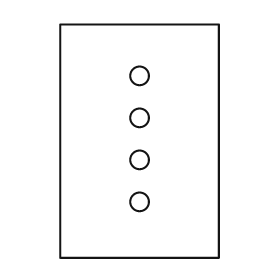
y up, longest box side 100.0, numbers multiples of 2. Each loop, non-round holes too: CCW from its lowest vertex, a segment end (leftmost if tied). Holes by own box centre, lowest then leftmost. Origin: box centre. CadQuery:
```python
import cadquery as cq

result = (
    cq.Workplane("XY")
    .moveTo(-34.0, -50.0)
    .lineTo(34.0, -50.0)
    .lineTo(34.0, 50.0)
    .lineTo(-34.0, 50.0)
    .close()
    .moveTo(0.0, -26.0)
    .circle(4.0)
    .moveTo(0.0, -8.0)
    .circle(4.0)
    .moveTo(0.0, 10.0)
    .circle(4.0)
    .moveTo(0.0, 28.0)
    .circle(4.0)
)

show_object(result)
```